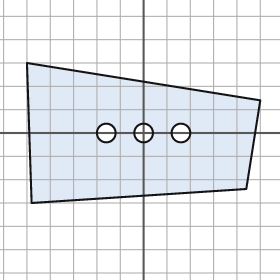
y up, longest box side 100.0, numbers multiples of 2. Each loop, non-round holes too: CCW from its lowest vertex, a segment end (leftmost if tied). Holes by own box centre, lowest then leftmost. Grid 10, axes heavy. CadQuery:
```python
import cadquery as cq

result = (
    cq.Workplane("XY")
    .moveTo(-48.0, -30.0)
    .lineTo(44.0, -24.0)
    .lineTo(50.0, 14.0)
    .lineTo(-50.0, 30.0)
    .close()
    .moveTo(-16.0, 0.0)
    .circle(4.0)
    .moveTo(0.0, 0.0)
    .circle(4.0)
    .moveTo(16.0, 0.0)
    .circle(4.0)
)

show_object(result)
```